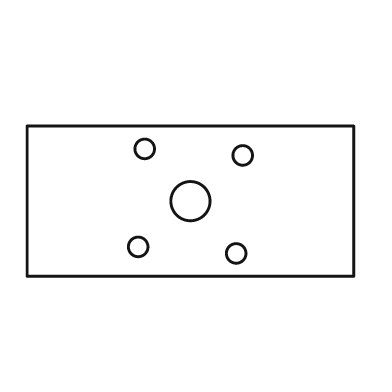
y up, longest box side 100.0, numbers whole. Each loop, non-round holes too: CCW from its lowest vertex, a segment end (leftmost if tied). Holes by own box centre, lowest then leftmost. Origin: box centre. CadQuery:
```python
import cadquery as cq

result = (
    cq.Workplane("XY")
    .moveTo(-50.0, -23.0)
    .lineTo(50.0, -23.0)
    .lineTo(50.0, 23.0)
    .lineTo(-50.0, 23.0)
    .close()
    .moveTo(14.0, -16.0)
    .circle(3.0)
    .moveTo(-16.0, -14.0)
    .circle(3.0)
    .moveTo(0.0, 0.0)
    .circle(6.0)
    .moveTo(16.0, 14.0)
    .circle(3.0)
    .moveTo(-14.0, 16.0)
    .circle(3.0)
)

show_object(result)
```